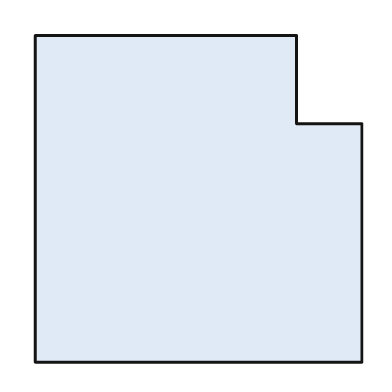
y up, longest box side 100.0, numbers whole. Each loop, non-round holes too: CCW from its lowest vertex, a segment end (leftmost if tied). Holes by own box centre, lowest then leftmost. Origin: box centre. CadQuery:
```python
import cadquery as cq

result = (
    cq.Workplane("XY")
    .moveTo(-50.0, -50.0)
    .lineTo(50.0, -50.0)
    .lineTo(50.0, 23.0)
    .lineTo(30.0, 23.0)
    .lineTo(30.0, 50.0)
    .lineTo(-50.0, 50.0)
    .close()
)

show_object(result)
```